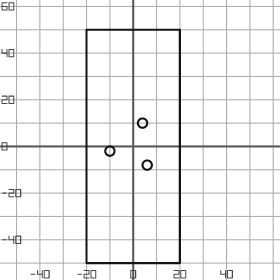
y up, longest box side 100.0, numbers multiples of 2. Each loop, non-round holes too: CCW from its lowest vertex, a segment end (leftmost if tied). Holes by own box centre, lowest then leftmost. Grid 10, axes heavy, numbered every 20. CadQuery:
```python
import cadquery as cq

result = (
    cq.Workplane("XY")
    .moveTo(-20.0, -50.0)
    .lineTo(20.0, -50.0)
    .lineTo(20.0, 50.0)
    .lineTo(-20.0, 50.0)
    .close()
    .moveTo(6.0, -8.0)
    .circle(2.0)
    .moveTo(-10.0, -2.0)
    .circle(2.0)
    .moveTo(4.0, 10.0)
    .circle(2.0)
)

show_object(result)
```